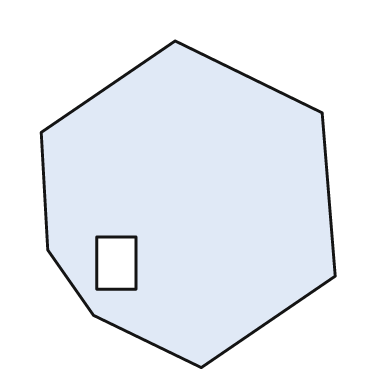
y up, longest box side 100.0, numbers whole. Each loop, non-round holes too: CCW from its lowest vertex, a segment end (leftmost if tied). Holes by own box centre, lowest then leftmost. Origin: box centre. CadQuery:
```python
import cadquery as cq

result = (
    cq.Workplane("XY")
    .moveTo(4.0, -50.0)
    .lineTo(45.0, -22.0)
    .lineTo(41.0, 28.0)
    .lineTo(-4.0, 50.0)
    .lineTo(-45.0, 22.0)
    .lineTo(-43.0, -14.0)
    .lineTo(-29.0, -34.0)
    .close()
    .moveTo(-28.0, -26.0)
    .lineTo(-16.0, -26.0)
    .lineTo(-16.0, -10.0)
    .lineTo(-28.0, -10.0)
    .close()
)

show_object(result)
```